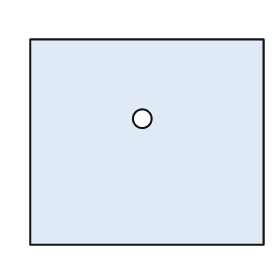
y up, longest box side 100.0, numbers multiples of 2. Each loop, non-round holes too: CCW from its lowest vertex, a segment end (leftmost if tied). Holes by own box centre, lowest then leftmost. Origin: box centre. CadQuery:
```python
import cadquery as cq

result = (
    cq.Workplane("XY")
    .moveTo(-50.0, -44.0)
    .lineTo(50.0, -44.0)
    .lineTo(50.0, 44.0)
    .lineTo(-50.0, 44.0)
    .close()
    .moveTo(-2.0, 10.0)
    .circle(4.0)
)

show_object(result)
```